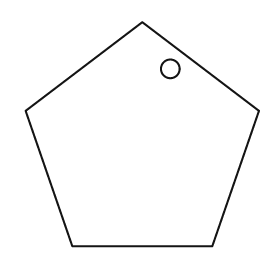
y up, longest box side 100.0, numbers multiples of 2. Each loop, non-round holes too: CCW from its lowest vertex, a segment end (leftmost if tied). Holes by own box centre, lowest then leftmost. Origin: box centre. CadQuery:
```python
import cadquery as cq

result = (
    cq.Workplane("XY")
    .moveTo(-30.0, -48.0)
    .lineTo(30.0, -48.0)
    .lineTo(50.0, 10.0)
    .lineTo(0.0, 48.0)
    .lineTo(-50.0, 10.0)
    .close()
    .moveTo(12.0, 28.0)
    .circle(4.0)
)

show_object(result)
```